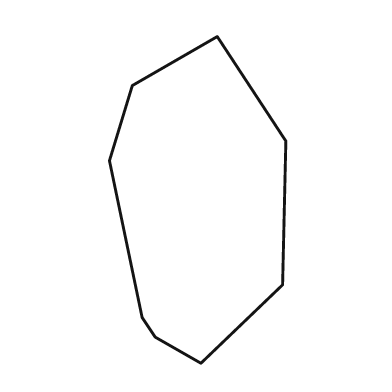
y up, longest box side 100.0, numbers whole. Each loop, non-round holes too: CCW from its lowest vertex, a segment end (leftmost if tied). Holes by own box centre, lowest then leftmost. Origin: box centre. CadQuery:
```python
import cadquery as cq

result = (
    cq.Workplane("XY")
    .moveTo(1.0, -50.0)
    .lineTo(26.0, -26.0)
    .lineTo(27.0, 18.0)
    .lineTo(6.0, 50.0)
    .lineTo(-20.0, 35.0)
    .lineTo(-27.0, 12.0)
    .lineTo(-17.0, -36.0)
    .lineTo(-13.0, -42.0)
    .close()
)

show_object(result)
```